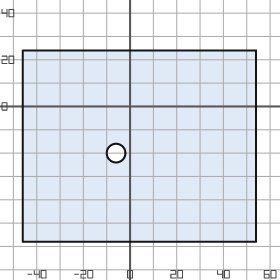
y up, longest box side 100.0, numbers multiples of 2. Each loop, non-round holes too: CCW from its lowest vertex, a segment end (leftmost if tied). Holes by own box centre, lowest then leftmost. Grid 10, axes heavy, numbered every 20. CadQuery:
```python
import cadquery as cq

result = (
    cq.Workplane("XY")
    .moveTo(-46.0, -58.0)
    .lineTo(54.0, -58.0)
    .lineTo(54.0, 24.0)
    .lineTo(-46.0, 24.0)
    .close()
    .moveTo(-6.0, -20.0)
    .circle(4.0)
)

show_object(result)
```